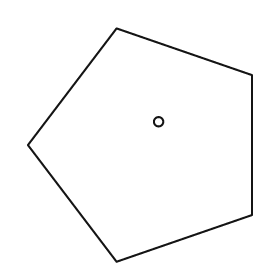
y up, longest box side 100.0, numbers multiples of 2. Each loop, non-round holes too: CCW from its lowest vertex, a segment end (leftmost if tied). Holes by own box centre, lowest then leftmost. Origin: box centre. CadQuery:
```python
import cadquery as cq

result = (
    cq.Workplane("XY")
    .moveTo(-10.0, -50.0)
    .lineTo(48.0, -30.0)
    .lineTo(48.0, 30.0)
    .lineTo(-10.0, 50.0)
    .lineTo(-48.0, 0.0)
    .close()
    .moveTo(8.0, 10.0)
    .circle(2.0)
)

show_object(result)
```